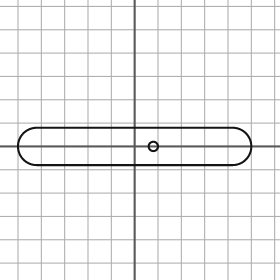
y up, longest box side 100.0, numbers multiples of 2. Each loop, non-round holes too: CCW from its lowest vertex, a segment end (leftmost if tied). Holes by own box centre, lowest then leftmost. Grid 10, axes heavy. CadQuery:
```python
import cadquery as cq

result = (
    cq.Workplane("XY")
    .moveTo(-42.0, -8.0)
    .lineTo(42.0, -8.0)
    .threePointArc((50.0, 0.0), (42.0, 8.0))
    .lineTo(-42.0, 8.0)
    .threePointArc((-50.0, 0.0), (-42.0, -8.0))
    .close()
    .moveTo(8.0, 0.0)
    .circle(2.0)
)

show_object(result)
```